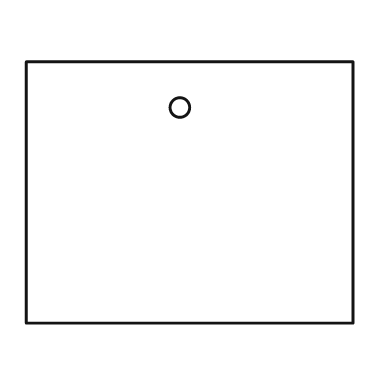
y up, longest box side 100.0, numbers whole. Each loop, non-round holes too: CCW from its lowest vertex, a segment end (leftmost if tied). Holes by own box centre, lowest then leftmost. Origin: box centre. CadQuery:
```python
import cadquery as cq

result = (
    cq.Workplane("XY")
    .moveTo(-50.0, -40.0)
    .lineTo(50.0, -40.0)
    .lineTo(50.0, 40.0)
    .lineTo(-50.0, 40.0)
    .close()
    .moveTo(-3.0, 26.0)
    .circle(3.0)
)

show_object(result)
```